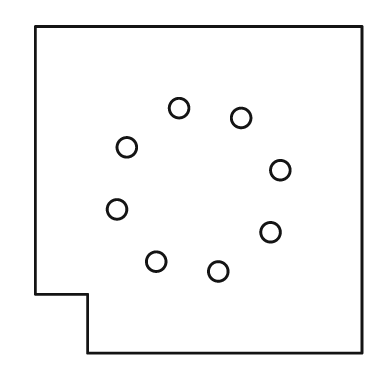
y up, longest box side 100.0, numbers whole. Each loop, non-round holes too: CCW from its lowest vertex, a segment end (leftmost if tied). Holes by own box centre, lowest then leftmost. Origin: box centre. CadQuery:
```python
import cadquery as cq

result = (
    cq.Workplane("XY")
    .moveTo(-34.0, -50.0)
    .lineTo(50.0, -50.0)
    .lineTo(50.0, 50.0)
    .lineTo(-50.0, 50.0)
    .lineTo(-50.0, -32.0)
    .lineTo(-34.0, -32.0)
    .close()
    .moveTo(6.0, -25.0)
    .circle(3.0)
    .moveTo(-13.0, -22.0)
    .circle(3.0)
    .moveTo(22.0, -13.0)
    .circle(3.0)
    .moveTo(-25.0, -6.0)
    .circle(3.0)
    .moveTo(25.0, 6.0)
    .circle(3.0)
    .moveTo(-22.0, 13.0)
    .circle(3.0)
    .moveTo(13.0, 22.0)
    .circle(3.0)
    .moveTo(-6.0, 25.0)
    .circle(3.0)
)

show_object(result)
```